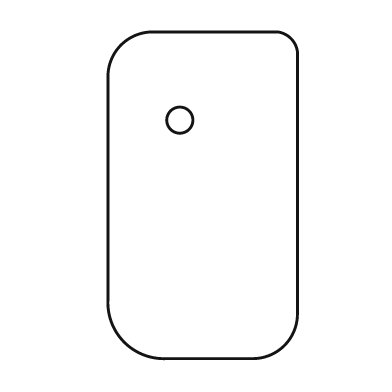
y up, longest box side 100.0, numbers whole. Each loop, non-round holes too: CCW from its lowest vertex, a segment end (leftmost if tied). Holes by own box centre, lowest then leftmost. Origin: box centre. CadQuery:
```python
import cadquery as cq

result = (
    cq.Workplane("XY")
    .moveTo(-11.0, -50.0)
    .lineTo(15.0, -50.0)
    .threePointArc((25.0, -46.0), (29.0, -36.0))
    .lineTo(29.0, 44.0)
    .threePointArc((27.0, 48.0), (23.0, 50.0))
    .lineTo(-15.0, 50.0)
    .threePointArc((-25.0, 46.0), (-29.0, 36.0))
    .lineTo(-29.0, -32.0)
    .threePointArc((-24.0, -45.0), (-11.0, -50.0))
    .close()
    .moveTo(-7.0, 23.0)
    .circle(4.0)
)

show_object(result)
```